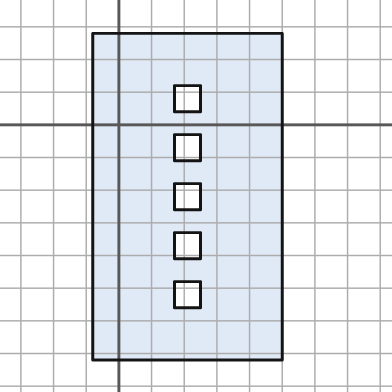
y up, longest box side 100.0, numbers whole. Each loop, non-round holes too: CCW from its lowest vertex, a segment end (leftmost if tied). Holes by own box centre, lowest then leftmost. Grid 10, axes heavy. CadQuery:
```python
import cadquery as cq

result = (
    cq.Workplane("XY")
    .moveTo(-8.0, -72.0)
    .lineTo(50.0, -72.0)
    .lineTo(50.0, 28.0)
    .lineTo(-8.0, 28.0)
    .close()
    .moveTo(17.0, -56.0)
    .lineTo(25.0, -56.0)
    .lineTo(25.0, -48.0)
    .lineTo(17.0, -48.0)
    .close()
    .moveTo(17.0, -41.0)
    .lineTo(25.0, -41.0)
    .lineTo(25.0, -33.0)
    .lineTo(17.0, -33.0)
    .close()
    .moveTo(17.0, -26.0)
    .lineTo(25.0, -26.0)
    .lineTo(25.0, -18.0)
    .lineTo(17.0, -18.0)
    .close()
    .moveTo(17.0, -11.0)
    .lineTo(25.0, -11.0)
    .lineTo(25.0, -3.0)
    .lineTo(17.0, -3.0)
    .close()
    .moveTo(17.0, 4.0)
    .lineTo(25.0, 4.0)
    .lineTo(25.0, 12.0)
    .lineTo(17.0, 12.0)
    .close()
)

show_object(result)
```